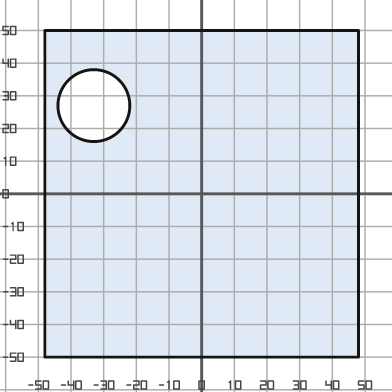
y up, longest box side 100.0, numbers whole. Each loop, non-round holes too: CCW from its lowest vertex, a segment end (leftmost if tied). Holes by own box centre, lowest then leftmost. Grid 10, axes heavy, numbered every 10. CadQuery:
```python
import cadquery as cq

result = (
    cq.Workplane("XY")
    .moveTo(-48.0, -50.0)
    .lineTo(48.0, -50.0)
    .lineTo(48.0, 50.0)
    .lineTo(-48.0, 50.0)
    .close()
    .moveTo(-33.0, 27.0)
    .circle(11.0)
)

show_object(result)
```